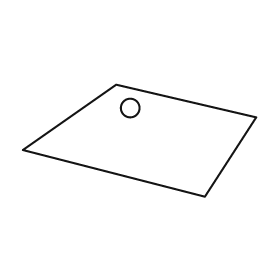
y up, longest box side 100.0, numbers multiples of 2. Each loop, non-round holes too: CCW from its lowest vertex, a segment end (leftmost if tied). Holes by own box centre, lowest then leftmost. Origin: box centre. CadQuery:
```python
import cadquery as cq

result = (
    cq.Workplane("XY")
    .moveTo(28.0, -24.0)
    .lineTo(50.0, 10.0)
    .lineTo(-10.0, 24.0)
    .lineTo(-50.0, -4.0)
    .close()
    .moveTo(-4.0, 14.0)
    .circle(4.0)
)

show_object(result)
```